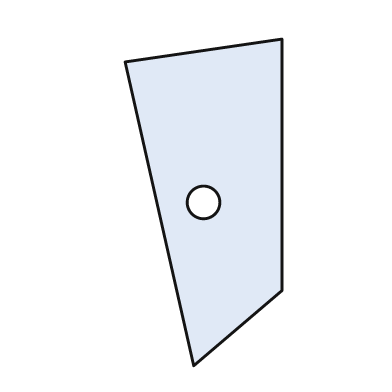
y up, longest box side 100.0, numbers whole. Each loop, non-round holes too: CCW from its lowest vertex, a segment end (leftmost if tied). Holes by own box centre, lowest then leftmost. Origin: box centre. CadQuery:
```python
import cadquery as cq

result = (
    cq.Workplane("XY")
    .moveTo(-3.0, -50.0)
    .lineTo(24.0, -27.0)
    .lineTo(24.0, 50.0)
    .lineTo(-24.0, 43.0)
    .close()
    .moveTo(0.0, 0.0)
    .circle(5.0)
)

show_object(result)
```